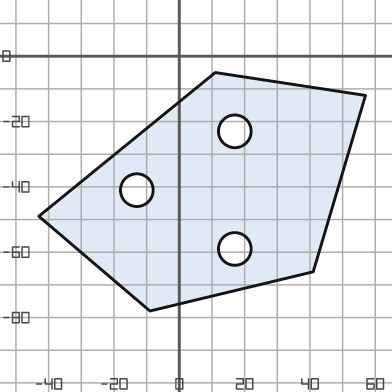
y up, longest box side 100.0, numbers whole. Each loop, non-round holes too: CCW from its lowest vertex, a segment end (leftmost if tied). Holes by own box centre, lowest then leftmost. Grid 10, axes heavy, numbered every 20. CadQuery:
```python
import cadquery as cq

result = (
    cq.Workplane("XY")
    .moveTo(-9.0, -78.0)
    .lineTo(41.0, -66.0)
    .lineTo(57.0, -12.0)
    .lineTo(11.0, -5.0)
    .lineTo(-43.0, -49.0)
    .close()
    .moveTo(17.0, -59.0)
    .circle(5.0)
    .moveTo(-13.0, -41.0)
    .circle(5.0)
    .moveTo(17.0, -23.0)
    .circle(5.0)
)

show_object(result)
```